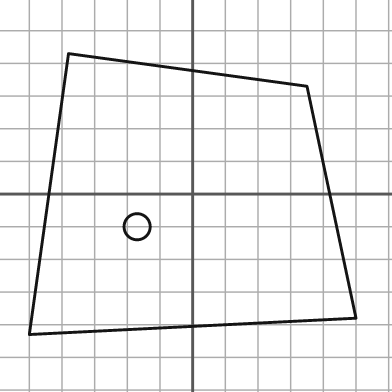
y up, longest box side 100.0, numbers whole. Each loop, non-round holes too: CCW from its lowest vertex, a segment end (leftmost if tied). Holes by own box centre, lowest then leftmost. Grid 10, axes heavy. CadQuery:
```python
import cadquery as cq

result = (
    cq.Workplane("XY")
    .moveTo(-50.0, -43.0)
    .lineTo(50.0, -38.0)
    .lineTo(35.0, 33.0)
    .lineTo(-38.0, 43.0)
    .close()
    .moveTo(-17.0, -10.0)
    .circle(4.0)
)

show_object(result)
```